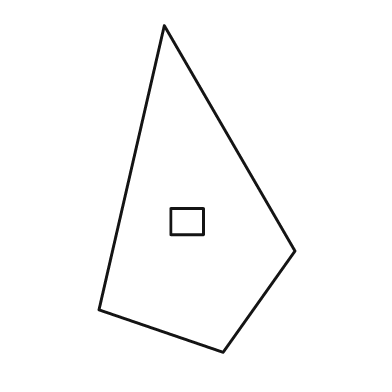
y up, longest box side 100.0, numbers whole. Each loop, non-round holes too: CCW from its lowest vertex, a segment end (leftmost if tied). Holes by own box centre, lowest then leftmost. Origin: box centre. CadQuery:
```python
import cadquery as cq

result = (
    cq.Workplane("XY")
    .moveTo(8.0, -50.0)
    .lineTo(30.0, -19.0)
    .lineTo(-10.0, 50.0)
    .lineTo(-30.0, -37.0)
    .close()
    .moveTo(-8.0, -14.0)
    .lineTo(2.0, -14.0)
    .lineTo(2.0, -6.0)
    .lineTo(-8.0, -6.0)
    .close()
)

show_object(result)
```